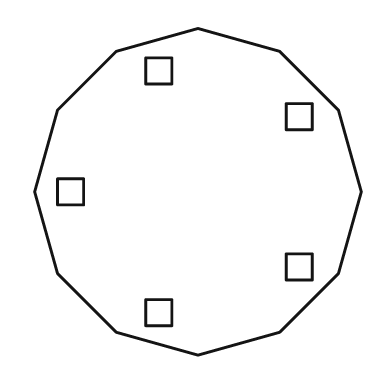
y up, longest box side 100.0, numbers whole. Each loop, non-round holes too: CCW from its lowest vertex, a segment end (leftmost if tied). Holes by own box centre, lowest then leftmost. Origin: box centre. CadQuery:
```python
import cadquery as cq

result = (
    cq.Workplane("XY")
    .moveTo(0.0, -50.0)
    .lineTo(25.0, -43.0)
    .lineTo(43.0, -25.0)
    .lineTo(50.0, 0.0)
    .lineTo(43.0, 25.0)
    .lineTo(25.0, 43.0)
    .lineTo(0.0, 50.0)
    .lineTo(-25.0, 43.0)
    .lineTo(-43.0, 25.0)
    .lineTo(-50.0, 0.0)
    .lineTo(-43.0, -25.0)
    .lineTo(-25.0, -43.0)
    .close()
    .moveTo(-16.0, -41.0)
    .lineTo(-8.0, -41.0)
    .lineTo(-8.0, -33.0)
    .lineTo(-16.0, -33.0)
    .close()
    .moveTo(27.0, -27.0)
    .lineTo(35.0, -27.0)
    .lineTo(35.0, -19.0)
    .lineTo(27.0, -19.0)
    .close()
    .moveTo(-43.0, -4.0)
    .lineTo(-35.0, -4.0)
    .lineTo(-35.0, 4.0)
    .lineTo(-43.0, 4.0)
    .close()
    .moveTo(27.0, 19.0)
    .lineTo(35.0, 19.0)
    .lineTo(35.0, 27.0)
    .lineTo(27.0, 27.0)
    .close()
    .moveTo(-16.0, 33.0)
    .lineTo(-8.0, 33.0)
    .lineTo(-8.0, 41.0)
    .lineTo(-16.0, 41.0)
    .close()
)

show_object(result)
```